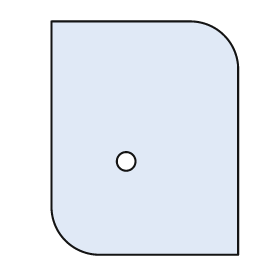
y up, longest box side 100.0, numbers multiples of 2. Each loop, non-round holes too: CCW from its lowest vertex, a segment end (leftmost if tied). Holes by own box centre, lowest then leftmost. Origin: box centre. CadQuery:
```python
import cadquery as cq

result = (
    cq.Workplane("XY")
    .moveTo(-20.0, -50.0)
    .lineTo(40.0, -50.0)
    .lineTo(40.0, 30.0)
    .threePointArc((34.0, 44.0), (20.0, 50.0))
    .lineTo(-40.0, 50.0)
    .lineTo(-40.0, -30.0)
    .threePointArc((-34.0, -44.0), (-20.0, -50.0))
    .close()
    .moveTo(-8.0, -10.0)
    .circle(4.0)
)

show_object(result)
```